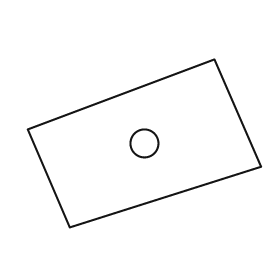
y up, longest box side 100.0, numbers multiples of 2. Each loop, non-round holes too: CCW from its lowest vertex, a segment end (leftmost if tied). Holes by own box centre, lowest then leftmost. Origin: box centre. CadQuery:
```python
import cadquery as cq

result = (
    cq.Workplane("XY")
    .moveTo(-32.0, -36.0)
    .lineTo(50.0, -10.0)
    .lineTo(30.0, 36.0)
    .lineTo(-50.0, 6.0)
    .close()
    .moveTo(0.0, 0.0)
    .circle(6.0)
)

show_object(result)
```